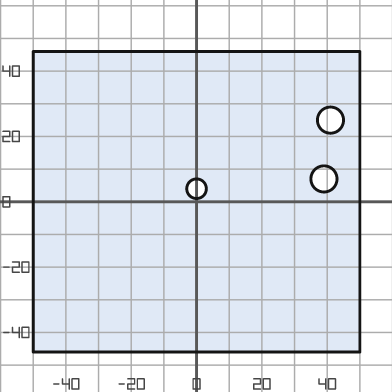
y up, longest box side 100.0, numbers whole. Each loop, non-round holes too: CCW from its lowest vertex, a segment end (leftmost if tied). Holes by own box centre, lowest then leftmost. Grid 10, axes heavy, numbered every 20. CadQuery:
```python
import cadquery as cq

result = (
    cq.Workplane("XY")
    .moveTo(-50.0, -46.0)
    .lineTo(50.0, -46.0)
    .lineTo(50.0, 46.0)
    .lineTo(-50.0, 46.0)
    .close()
    .moveTo(0.0, 4.0)
    .circle(3.0)
    .moveTo(39.0, 7.0)
    .circle(4.0)
    .moveTo(41.0, 25.0)
    .circle(4.0)
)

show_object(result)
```